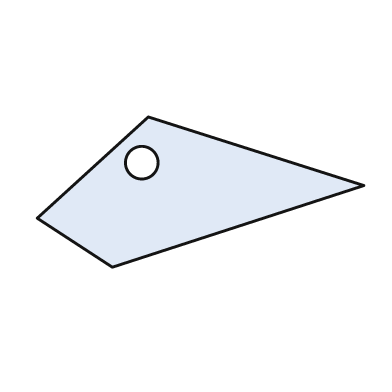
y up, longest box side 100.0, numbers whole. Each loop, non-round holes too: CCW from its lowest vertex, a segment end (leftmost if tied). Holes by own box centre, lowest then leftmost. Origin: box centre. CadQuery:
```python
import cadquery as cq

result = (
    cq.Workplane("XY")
    .moveTo(-27.0, -23.0)
    .lineTo(50.0, 2.0)
    .lineTo(-16.0, 23.0)
    .lineTo(-50.0, -8.0)
    .close()
    .moveTo(-18.0, 9.0)
    .circle(5.0)
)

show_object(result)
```